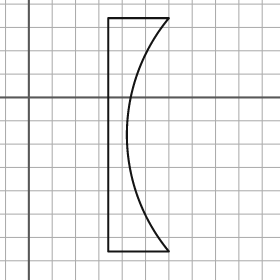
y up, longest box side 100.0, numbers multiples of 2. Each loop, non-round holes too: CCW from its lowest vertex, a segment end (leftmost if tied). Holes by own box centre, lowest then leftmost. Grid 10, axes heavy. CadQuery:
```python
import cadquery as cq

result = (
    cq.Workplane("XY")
    .moveTo(34.0, -66.0)
    .lineTo(60.0, -66.0)
    .threePointArc((42.0, -16.0), (60.0, 34.0))
    .lineTo(34.0, 34.0)
    .close()
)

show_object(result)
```